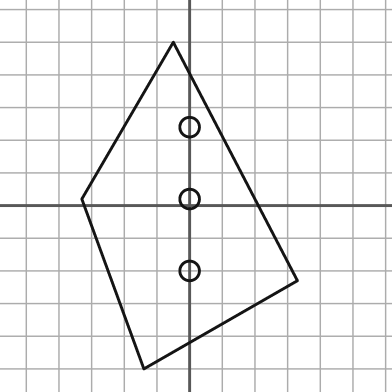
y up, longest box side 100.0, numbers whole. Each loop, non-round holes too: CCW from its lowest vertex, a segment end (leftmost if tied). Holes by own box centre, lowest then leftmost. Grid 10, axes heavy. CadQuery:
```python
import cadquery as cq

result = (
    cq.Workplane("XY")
    .moveTo(-14.0, -50.0)
    .lineTo(33.0, -23.0)
    .lineTo(-5.0, 50.0)
    .lineTo(-33.0, 2.0)
    .close()
    .moveTo(0.0, -20.0)
    .circle(3.0)
    .moveTo(0.0, 2.0)
    .circle(3.0)
    .moveTo(0.0, 24.0)
    .circle(3.0)
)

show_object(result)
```